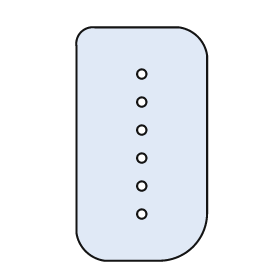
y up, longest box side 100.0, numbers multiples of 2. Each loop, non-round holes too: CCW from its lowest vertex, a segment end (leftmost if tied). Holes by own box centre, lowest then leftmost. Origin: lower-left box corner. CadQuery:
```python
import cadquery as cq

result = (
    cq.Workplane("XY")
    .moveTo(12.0, 0.0)
    .lineTo(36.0, 0.0)
    .threePointArc((50.0, 6.0), (56.0, 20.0))
    .lineTo(56.0, 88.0)
    .threePointArc((52.0, 96.0), (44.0, 100.0))
    .lineTo(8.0, 100.0)
    .threePointArc((2.0, 98.0), (0.0, 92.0))
    .lineTo(0.0, 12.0)
    .threePointArc((4.0, 4.0), (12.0, 0.0))
    .close()
    .moveTo(28.0, 20.0)
    .circle(2.0)
    .moveTo(28.0, 32.0)
    .circle(2.0)
    .moveTo(28.0, 44.0)
    .circle(2.0)
    .moveTo(28.0, 56.0)
    .circle(2.0)
    .moveTo(28.0, 68.0)
    .circle(2.0)
    .moveTo(28.0, 80.0)
    .circle(2.0)
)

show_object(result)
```